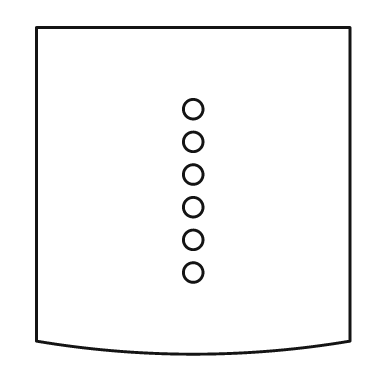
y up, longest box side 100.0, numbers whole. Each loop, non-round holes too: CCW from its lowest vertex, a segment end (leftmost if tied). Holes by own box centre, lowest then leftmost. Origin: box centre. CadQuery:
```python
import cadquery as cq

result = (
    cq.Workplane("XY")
    .moveTo(-48.0, -46.0)
    .threePointArc((0.0, -50.0), (48.0, -46.0))
    .lineTo(48.0, 50.0)
    .lineTo(-48.0, 50.0)
    .close()
    .moveTo(0.0, -25.0)
    .circle(3.0)
    .moveTo(0.0, -15.0)
    .circle(3.0)
    .moveTo(0.0, -5.0)
    .circle(3.0)
    .moveTo(0.0, 5.0)
    .circle(3.0)
    .moveTo(0.0, 15.0)
    .circle(3.0)
    .moveTo(0.0, 25.0)
    .circle(3.0)
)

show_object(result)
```